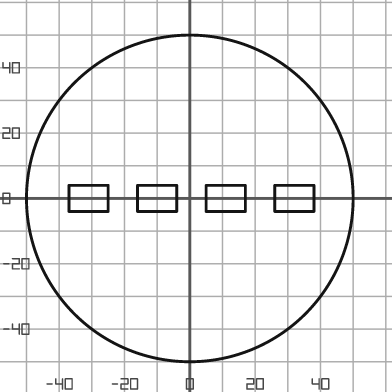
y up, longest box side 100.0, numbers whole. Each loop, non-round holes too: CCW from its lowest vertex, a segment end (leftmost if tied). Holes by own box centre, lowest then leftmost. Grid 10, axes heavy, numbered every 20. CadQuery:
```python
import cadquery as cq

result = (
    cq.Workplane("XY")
    .moveTo(0.0, 0.0)
    .circle(50.0)
    .moveTo(-37.0, -4.0)
    .lineTo(-25.0, -4.0)
    .lineTo(-25.0, 4.0)
    .lineTo(-37.0, 4.0)
    .close()
    .moveTo(-16.0, -4.0)
    .lineTo(-4.0, -4.0)
    .lineTo(-4.0, 4.0)
    .lineTo(-16.0, 4.0)
    .close()
    .moveTo(5.0, -4.0)
    .lineTo(17.0, -4.0)
    .lineTo(17.0, 4.0)
    .lineTo(5.0, 4.0)
    .close()
    .moveTo(26.0, -4.0)
    .lineTo(38.0, -4.0)
    .lineTo(38.0, 4.0)
    .lineTo(26.0, 4.0)
    .close()
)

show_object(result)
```